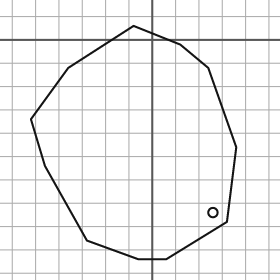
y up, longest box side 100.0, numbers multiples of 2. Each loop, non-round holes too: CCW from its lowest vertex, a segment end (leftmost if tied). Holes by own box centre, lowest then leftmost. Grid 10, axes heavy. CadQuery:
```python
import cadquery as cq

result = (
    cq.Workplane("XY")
    .moveTo(-6.0, -94.0)
    .lineTo(6.0, -94.0)
    .lineTo(32.0, -78.0)
    .lineTo(36.0, -46.0)
    .lineTo(24.0, -12.0)
    .lineTo(12.0, -2.0)
    .lineTo(-8.0, 6.0)
    .lineTo(-36.0, -12.0)
    .lineTo(-52.0, -34.0)
    .lineTo(-46.0, -54.0)
    .lineTo(-28.0, -86.0)
    .close()
    .moveTo(26.0, -74.0)
    .circle(2.0)
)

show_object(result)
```